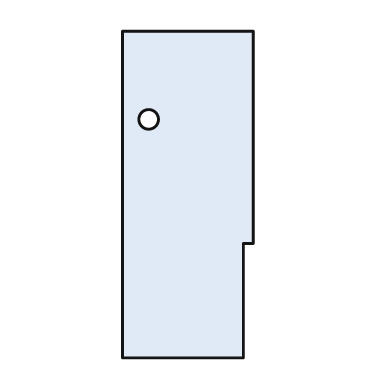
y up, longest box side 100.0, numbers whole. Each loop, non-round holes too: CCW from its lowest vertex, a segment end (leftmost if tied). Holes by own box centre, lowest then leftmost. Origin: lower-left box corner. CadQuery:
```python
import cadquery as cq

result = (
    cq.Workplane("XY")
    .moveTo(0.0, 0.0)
    .lineTo(37.0, 0.0)
    .lineTo(37.0, 35.0)
    .lineTo(40.0, 35.0)
    .lineTo(40.0, 100.0)
    .lineTo(0.0, 100.0)
    .close()
    .moveTo(8.0, 73.0)
    .circle(3.0)
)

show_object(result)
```